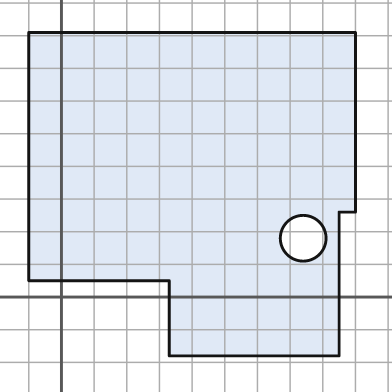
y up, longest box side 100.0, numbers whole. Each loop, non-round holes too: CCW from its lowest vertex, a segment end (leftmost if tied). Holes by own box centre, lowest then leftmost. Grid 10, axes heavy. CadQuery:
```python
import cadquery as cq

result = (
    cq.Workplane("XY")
    .moveTo(33.0, -18.0)
    .lineTo(85.0, -18.0)
    .lineTo(85.0, 26.0)
    .lineTo(90.0, 26.0)
    .lineTo(90.0, 81.0)
    .lineTo(-10.0, 81.0)
    .lineTo(-10.0, 5.0)
    .lineTo(33.0, 5.0)
    .close()
    .moveTo(74.0, 18.0)
    .circle(7.0)
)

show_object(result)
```